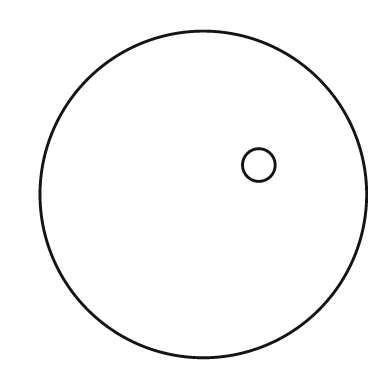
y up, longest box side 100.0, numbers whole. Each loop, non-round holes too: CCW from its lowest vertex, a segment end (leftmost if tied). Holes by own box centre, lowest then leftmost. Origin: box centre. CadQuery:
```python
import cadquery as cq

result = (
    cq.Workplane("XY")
    .moveTo(0.0, 0.0)
    .circle(50.0)
    .moveTo(17.0, 9.0)
    .circle(5.0)
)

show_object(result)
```